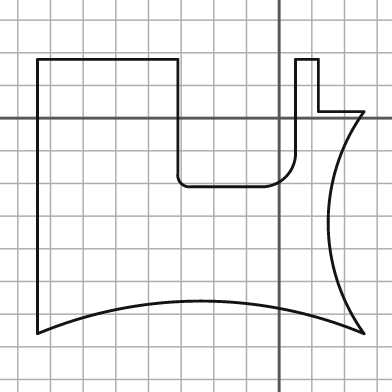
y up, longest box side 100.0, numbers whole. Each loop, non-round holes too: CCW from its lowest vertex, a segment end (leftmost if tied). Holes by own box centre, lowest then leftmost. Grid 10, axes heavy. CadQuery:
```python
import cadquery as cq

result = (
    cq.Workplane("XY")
    .moveTo(-74.0, -66.0)
    .threePointArc((-24.0, -56.0), (26.0, -66.0))
    .threePointArc((15.0, -32.0), (26.0, 2.0))
    .lineTo(12.0, 2.0)
    .lineTo(12.0, 18.0)
    .lineTo(5.0, 18.0)
    .lineTo(5.0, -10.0)
    .threePointArc((2.0, -18.0), (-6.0, -21.0))
    .lineTo(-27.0, -21.0)
    .threePointArc((-30.0, -20.0), (-31.0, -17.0))
    .lineTo(-31.0, 18.0)
    .lineTo(-74.0, 18.0)
    .close()
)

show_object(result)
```